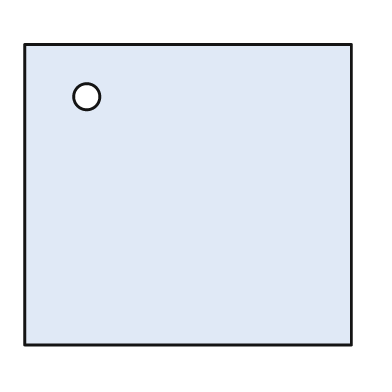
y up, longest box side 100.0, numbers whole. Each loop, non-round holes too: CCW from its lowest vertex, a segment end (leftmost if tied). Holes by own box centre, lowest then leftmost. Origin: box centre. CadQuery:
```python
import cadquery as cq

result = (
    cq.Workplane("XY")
    .moveTo(-50.0, -46.0)
    .lineTo(50.0, -46.0)
    .lineTo(50.0, 46.0)
    .lineTo(-50.0, 46.0)
    .close()
    .moveTo(-31.0, 30.0)
    .circle(4.0)
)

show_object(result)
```